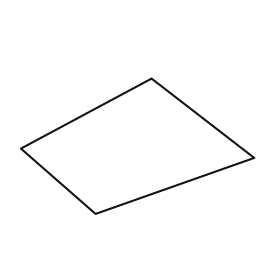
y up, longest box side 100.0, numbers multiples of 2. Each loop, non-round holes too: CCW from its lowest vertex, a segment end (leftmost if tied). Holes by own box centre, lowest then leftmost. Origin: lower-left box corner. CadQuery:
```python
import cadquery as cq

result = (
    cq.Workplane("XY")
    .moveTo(32.0, 0.0)
    .lineTo(100.0, 24.0)
    .lineTo(56.0, 58.0)
    .lineTo(0.0, 28.0)
    .close()
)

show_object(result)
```